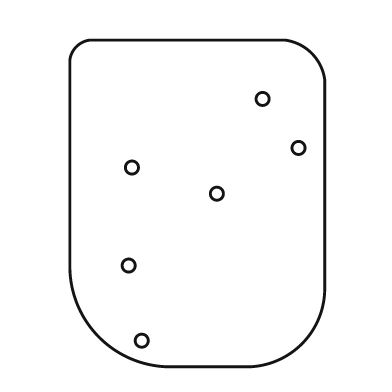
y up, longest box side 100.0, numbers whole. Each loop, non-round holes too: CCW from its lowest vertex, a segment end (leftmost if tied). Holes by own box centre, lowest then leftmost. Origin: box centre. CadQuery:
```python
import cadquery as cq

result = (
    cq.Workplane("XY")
    .moveTo(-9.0, -50.0)
    .lineTo(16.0, -50.0)
    .threePointArc((32.0, -43.0), (39.0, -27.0))
    .lineTo(39.0, 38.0)
    .threePointArc((35.0, 46.0), (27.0, 50.0))
    .lineTo(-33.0, 50.0)
    .threePointArc((-37.0, 48.0), (-39.0, 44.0))
    .lineTo(-39.0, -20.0)
    .threePointArc((-30.0, -41.0), (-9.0, -50.0))
    .close()
    .moveTo(-17.0, -42.0)
    .circle(2.0)
    .moveTo(-21.0, -19.0)
    .circle(2.0)
    .moveTo(6.0, 3.0)
    .circle(2.0)
    .moveTo(-20.0, 11.0)
    .circle(2.0)
    .moveTo(31.0, 17.0)
    .circle(2.0)
    .moveTo(20.0, 32.0)
    .circle(2.0)
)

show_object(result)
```